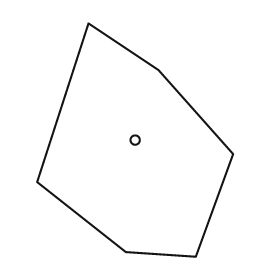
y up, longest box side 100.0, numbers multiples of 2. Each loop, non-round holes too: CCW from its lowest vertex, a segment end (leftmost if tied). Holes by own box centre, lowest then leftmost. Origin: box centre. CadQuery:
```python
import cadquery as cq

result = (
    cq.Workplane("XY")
    .moveTo(26.0, -50.0)
    .lineTo(42.0, -6.0)
    .lineTo(10.0, 30.0)
    .lineTo(-20.0, 50.0)
    .lineTo(-42.0, -18.0)
    .lineTo(-4.0, -48.0)
    .close()
    .moveTo(0.0, 0.0)
    .circle(2.0)
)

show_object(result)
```